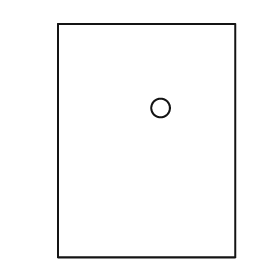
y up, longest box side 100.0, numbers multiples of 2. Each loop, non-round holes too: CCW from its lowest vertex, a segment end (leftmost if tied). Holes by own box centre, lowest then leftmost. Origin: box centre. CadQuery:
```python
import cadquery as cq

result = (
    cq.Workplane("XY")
    .moveTo(-38.0, -50.0)
    .lineTo(38.0, -50.0)
    .lineTo(38.0, 50.0)
    .lineTo(-38.0, 50.0)
    .close()
    .moveTo(6.0, 14.0)
    .circle(4.0)
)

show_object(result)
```